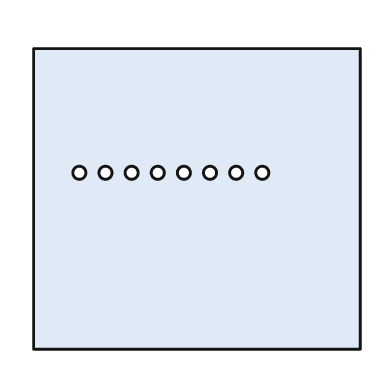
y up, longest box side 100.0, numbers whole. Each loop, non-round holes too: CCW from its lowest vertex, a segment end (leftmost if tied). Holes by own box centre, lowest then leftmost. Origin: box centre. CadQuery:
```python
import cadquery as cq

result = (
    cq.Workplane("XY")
    .moveTo(-50.0, -46.0)
    .lineTo(50.0, -46.0)
    .lineTo(50.0, 46.0)
    .lineTo(-50.0, 46.0)
    .close()
    .moveTo(-36.0, 8.0)
    .circle(2.0)
    .moveTo(-28.0, 8.0)
    .circle(2.0)
    .moveTo(-20.0, 8.0)
    .circle(2.0)
    .moveTo(-12.0, 8.0)
    .circle(2.0)
    .moveTo(-4.0, 8.0)
    .circle(2.0)
    .moveTo(4.0, 8.0)
    .circle(2.0)
    .moveTo(12.0, 8.0)
    .circle(2.0)
    .moveTo(20.0, 8.0)
    .circle(2.0)
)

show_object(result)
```